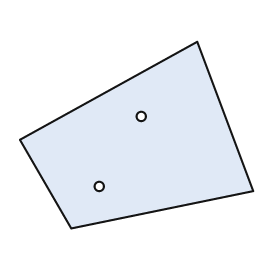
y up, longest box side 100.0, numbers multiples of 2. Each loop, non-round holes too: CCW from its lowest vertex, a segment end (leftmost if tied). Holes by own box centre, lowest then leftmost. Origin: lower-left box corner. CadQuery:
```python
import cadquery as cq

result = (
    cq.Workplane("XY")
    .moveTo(22.0, 0.0)
    .lineTo(100.0, 16.0)
    .lineTo(76.0, 80.0)
    .lineTo(0.0, 38.0)
    .close()
    .moveTo(34.0, 18.0)
    .circle(2.0)
    .moveTo(52.0, 48.0)
    .circle(2.0)
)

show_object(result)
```